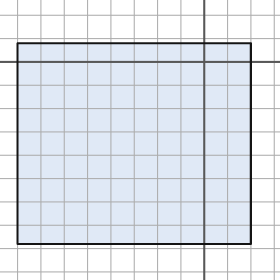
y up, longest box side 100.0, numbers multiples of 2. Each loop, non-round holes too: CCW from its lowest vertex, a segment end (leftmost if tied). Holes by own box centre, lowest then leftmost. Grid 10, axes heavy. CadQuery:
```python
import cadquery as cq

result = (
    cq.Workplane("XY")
    .moveTo(-80.0, -78.0)
    .lineTo(20.0, -78.0)
    .lineTo(20.0, 8.0)
    .lineTo(-80.0, 8.0)
    .close()
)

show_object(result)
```